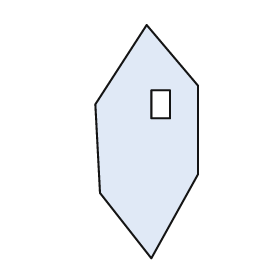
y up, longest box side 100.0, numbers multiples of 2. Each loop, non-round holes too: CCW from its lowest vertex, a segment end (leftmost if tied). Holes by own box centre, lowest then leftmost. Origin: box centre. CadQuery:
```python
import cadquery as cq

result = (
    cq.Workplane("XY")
    .moveTo(2.0, -50.0)
    .lineTo(22.0, -14.0)
    .lineTo(22.0, 24.0)
    .lineTo(0.0, 50.0)
    .lineTo(-22.0, 16.0)
    .lineTo(-20.0, -22.0)
    .close()
    .moveTo(2.0, 10.0)
    .lineTo(10.0, 10.0)
    .lineTo(10.0, 22.0)
    .lineTo(2.0, 22.0)
    .close()
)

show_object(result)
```